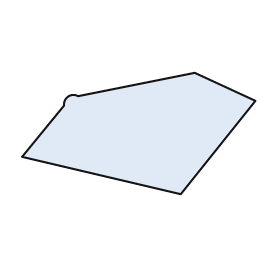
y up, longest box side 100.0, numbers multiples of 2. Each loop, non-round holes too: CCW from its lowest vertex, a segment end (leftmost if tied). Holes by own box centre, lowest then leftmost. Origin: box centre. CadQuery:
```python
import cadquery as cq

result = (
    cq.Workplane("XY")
    .moveTo(18.0, -26.0)
    .lineTo(50.0, 14.0)
    .lineTo(24.0, 26.0)
    .lineTo(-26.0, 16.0)
    .threePointArc((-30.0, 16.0), (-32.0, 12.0))
    .lineTo(-50.0, -10.0)
    .close()
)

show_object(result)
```